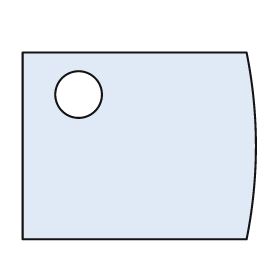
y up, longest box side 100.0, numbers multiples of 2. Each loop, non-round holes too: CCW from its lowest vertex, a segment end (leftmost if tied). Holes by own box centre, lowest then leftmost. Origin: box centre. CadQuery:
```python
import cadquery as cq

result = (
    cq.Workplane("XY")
    .moveTo(-50.0, -40.0)
    .lineTo(46.0, -40.0)
    .threePointArc((50.0, 0.0), (46.0, 40.0))
    .lineTo(-50.0, 40.0)
    .close()
    .moveTo(-26.0, 22.0)
    .circle(10.0)
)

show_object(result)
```